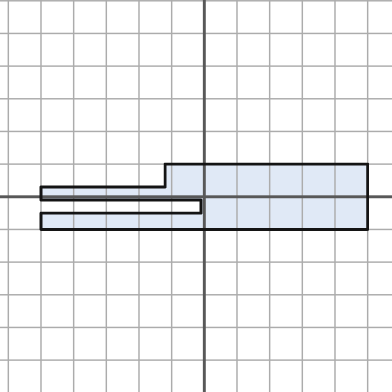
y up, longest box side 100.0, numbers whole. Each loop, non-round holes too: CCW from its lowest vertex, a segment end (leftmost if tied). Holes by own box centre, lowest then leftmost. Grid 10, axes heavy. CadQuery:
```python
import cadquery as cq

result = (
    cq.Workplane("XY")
    .moveTo(-50.0, -10.0)
    .lineTo(50.0, -10.0)
    .lineTo(50.0, 10.0)
    .lineTo(-12.0, 10.0)
    .lineTo(-12.0, 3.0)
    .lineTo(-50.0, 3.0)
    .lineTo(-50.0, -1.0)
    .lineTo(-1.0, -1.0)
    .lineTo(-1.0, -5.0)
    .lineTo(-50.0, -5.0)
    .close()
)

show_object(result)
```